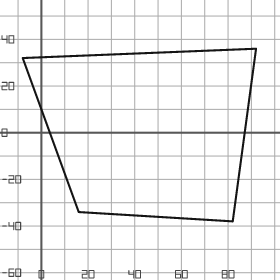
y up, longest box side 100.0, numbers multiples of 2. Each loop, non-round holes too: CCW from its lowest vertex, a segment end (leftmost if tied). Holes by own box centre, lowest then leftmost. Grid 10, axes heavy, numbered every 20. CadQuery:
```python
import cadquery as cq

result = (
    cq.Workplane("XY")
    .moveTo(82.0, -38.0)
    .lineTo(92.0, 36.0)
    .lineTo(-8.0, 32.0)
    .lineTo(16.0, -34.0)
    .close()
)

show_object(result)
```